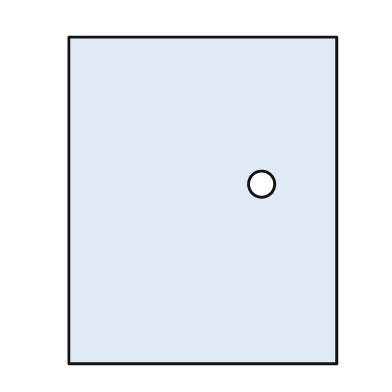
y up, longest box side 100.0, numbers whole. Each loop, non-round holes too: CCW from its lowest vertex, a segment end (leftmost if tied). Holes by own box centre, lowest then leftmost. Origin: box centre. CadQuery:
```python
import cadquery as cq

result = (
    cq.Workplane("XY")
    .moveTo(-41.0, -50.0)
    .lineTo(41.0, -50.0)
    .lineTo(41.0, 50.0)
    .lineTo(-41.0, 50.0)
    .close()
    .moveTo(18.0, 5.0)
    .circle(4.0)
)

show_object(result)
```